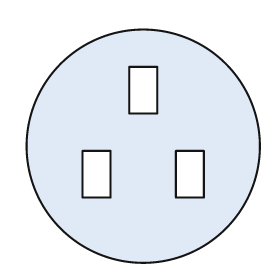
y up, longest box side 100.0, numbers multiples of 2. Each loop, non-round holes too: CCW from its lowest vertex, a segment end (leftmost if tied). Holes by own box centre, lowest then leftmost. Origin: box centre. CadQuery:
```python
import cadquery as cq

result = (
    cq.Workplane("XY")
    .moveTo(0.0, 0.0)
    .circle(50.0)
    .moveTo(-26.0, -22.0)
    .lineTo(-14.0, -22.0)
    .lineTo(-14.0, -2.0)
    .lineTo(-26.0, -2.0)
    .close()
    .moveTo(14.0, -22.0)
    .lineTo(26.0, -22.0)
    .lineTo(26.0, -2.0)
    .lineTo(14.0, -2.0)
    .close()
    .moveTo(-6.0, 14.0)
    .lineTo(6.0, 14.0)
    .lineTo(6.0, 34.0)
    .lineTo(-6.0, 34.0)
    .close()
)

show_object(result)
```